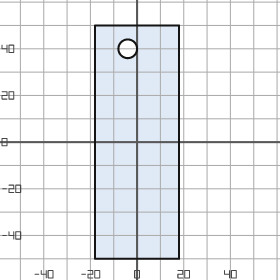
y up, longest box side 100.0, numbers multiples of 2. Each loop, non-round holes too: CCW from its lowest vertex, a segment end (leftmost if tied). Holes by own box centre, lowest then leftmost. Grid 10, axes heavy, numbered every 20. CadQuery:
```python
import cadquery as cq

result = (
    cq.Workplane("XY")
    .moveTo(-18.0, -50.0)
    .lineTo(18.0, -50.0)
    .lineTo(18.0, 50.0)
    .lineTo(-18.0, 50.0)
    .close()
    .moveTo(-4.0, 40.0)
    .circle(4.0)
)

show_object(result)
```